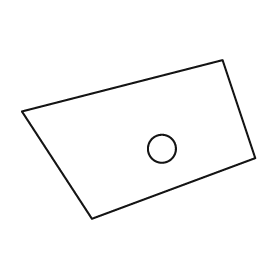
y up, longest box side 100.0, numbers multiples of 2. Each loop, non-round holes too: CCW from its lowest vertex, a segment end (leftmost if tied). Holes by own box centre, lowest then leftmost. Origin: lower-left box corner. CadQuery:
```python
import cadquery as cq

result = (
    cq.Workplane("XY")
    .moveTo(30.0, 0.0)
    .lineTo(100.0, 26.0)
    .lineTo(86.0, 68.0)
    .lineTo(0.0, 46.0)
    .close()
    .moveTo(60.0, 30.0)
    .circle(6.0)
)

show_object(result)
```